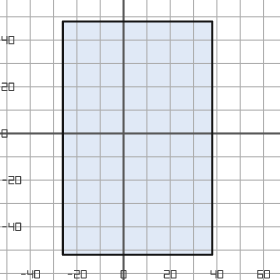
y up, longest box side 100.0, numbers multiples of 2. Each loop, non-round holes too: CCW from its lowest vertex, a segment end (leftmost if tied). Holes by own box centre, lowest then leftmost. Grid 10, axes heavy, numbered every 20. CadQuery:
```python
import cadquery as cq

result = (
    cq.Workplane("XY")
    .moveTo(-26.0, -52.0)
    .lineTo(38.0, -52.0)
    .lineTo(38.0, 48.0)
    .lineTo(-26.0, 48.0)
    .close()
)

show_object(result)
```